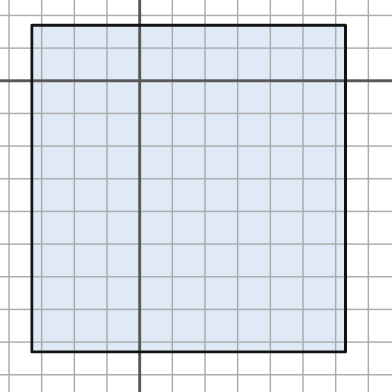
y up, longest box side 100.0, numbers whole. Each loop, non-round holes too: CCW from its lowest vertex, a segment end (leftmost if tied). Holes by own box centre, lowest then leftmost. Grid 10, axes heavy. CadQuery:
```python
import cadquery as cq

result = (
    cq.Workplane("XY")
    .moveTo(-33.0, -83.0)
    .lineTo(63.0, -83.0)
    .lineTo(63.0, 17.0)
    .lineTo(-33.0, 17.0)
    .close()
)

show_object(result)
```